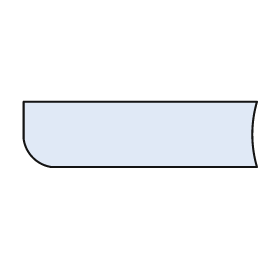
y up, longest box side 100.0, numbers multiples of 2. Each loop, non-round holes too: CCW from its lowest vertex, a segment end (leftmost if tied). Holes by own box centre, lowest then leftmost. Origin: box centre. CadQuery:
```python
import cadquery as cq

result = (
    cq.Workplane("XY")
    .moveTo(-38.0, -14.0)
    .lineTo(50.0, -14.0)
    .threePointArc((48.0, 0.0), (50.0, 14.0))
    .lineTo(-50.0, 14.0)
    .lineTo(-50.0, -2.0)
    .threePointArc((-46.0, -10.0), (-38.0, -14.0))
    .close()
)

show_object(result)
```